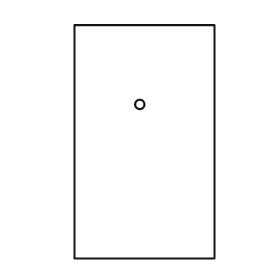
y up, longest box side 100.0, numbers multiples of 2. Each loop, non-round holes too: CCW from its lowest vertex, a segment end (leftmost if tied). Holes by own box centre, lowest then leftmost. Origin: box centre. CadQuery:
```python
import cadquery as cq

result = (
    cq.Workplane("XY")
    .moveTo(-30.0, -50.0)
    .lineTo(30.0, -50.0)
    .lineTo(30.0, 50.0)
    .lineTo(-30.0, 50.0)
    .close()
    .moveTo(-2.0, 16.0)
    .circle(2.0)
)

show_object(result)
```